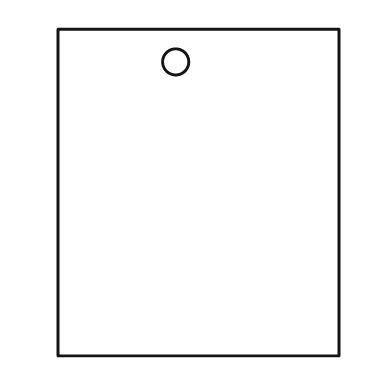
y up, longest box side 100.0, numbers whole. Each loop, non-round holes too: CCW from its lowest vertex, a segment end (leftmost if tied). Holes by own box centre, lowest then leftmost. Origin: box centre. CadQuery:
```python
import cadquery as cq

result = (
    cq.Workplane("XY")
    .moveTo(-43.0, -50.0)
    .lineTo(43.0, -50.0)
    .lineTo(43.0, 50.0)
    .lineTo(-43.0, 50.0)
    .close()
    .moveTo(-7.0, 40.0)
    .circle(4.0)
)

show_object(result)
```